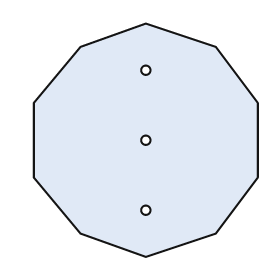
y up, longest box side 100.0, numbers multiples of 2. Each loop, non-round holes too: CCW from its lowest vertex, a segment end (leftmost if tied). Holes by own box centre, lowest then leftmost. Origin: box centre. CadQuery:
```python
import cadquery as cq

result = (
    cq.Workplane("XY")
    .moveTo(0.0, -50.0)
    .lineTo(30.0, -40.0)
    .lineTo(48.0, -16.0)
    .lineTo(48.0, 16.0)
    .lineTo(30.0, 40.0)
    .lineTo(0.0, 50.0)
    .lineTo(-28.0, 40.0)
    .lineTo(-48.0, 16.0)
    .lineTo(-48.0, -16.0)
    .lineTo(-28.0, -40.0)
    .close()
    .moveTo(0.0, -30.0)
    .circle(2.0)
    .moveTo(0.0, 0.0)
    .circle(2.0)
    .moveTo(0.0, 30.0)
    .circle(2.0)
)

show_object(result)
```